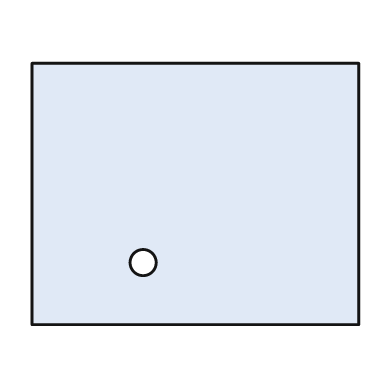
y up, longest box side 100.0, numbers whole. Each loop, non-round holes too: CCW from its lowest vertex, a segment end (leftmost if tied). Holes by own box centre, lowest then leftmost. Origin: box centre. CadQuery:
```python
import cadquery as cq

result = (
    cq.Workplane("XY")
    .moveTo(-50.0, -40.0)
    .lineTo(50.0, -40.0)
    .lineTo(50.0, 40.0)
    .lineTo(-50.0, 40.0)
    .close()
    .moveTo(-16.0, -21.0)
    .circle(4.0)
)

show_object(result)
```